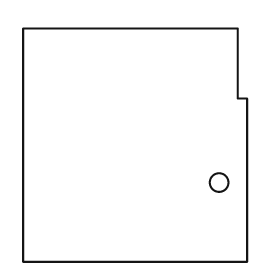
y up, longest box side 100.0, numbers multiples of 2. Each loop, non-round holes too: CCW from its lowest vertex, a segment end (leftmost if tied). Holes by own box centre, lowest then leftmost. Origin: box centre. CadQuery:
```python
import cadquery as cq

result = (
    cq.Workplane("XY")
    .moveTo(-48.0, -50.0)
    .lineTo(48.0, -50.0)
    .lineTo(48.0, 20.0)
    .lineTo(44.0, 20.0)
    .lineTo(44.0, 50.0)
    .lineTo(-48.0, 50.0)
    .close()
    .moveTo(36.0, -16.0)
    .circle(4.0)
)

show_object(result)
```